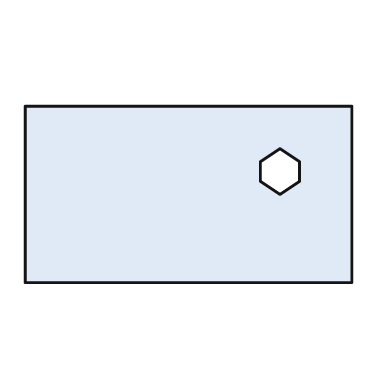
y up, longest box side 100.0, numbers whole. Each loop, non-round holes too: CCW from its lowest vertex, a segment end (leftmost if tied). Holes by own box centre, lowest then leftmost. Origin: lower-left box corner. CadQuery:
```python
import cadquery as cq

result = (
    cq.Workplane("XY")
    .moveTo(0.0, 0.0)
    .lineTo(100.0, 0.0)
    .lineTo(100.0, 54.0)
    .lineTo(0.0, 54.0)
    .close()
    .moveTo(78.0, 27.0)
    .lineTo(84.0, 31.0)
    .lineTo(84.0, 37.0)
    .lineTo(78.0, 41.0)
    .lineTo(72.0, 37.0)
    .lineTo(72.0, 31.0)
    .close()
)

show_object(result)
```